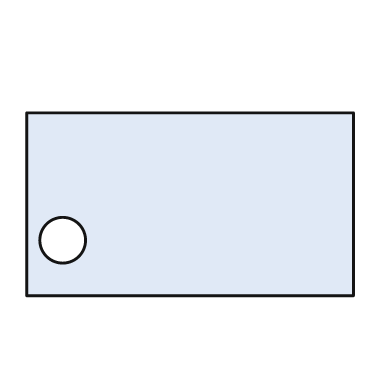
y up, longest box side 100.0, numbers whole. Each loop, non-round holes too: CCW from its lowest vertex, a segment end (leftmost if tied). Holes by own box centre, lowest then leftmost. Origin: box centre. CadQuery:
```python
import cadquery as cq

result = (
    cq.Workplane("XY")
    .moveTo(-50.0, -28.0)
    .lineTo(50.0, -28.0)
    .lineTo(50.0, 28.0)
    .lineTo(-50.0, 28.0)
    .close()
    .moveTo(-39.0, -11.0)
    .circle(7.0)
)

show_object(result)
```